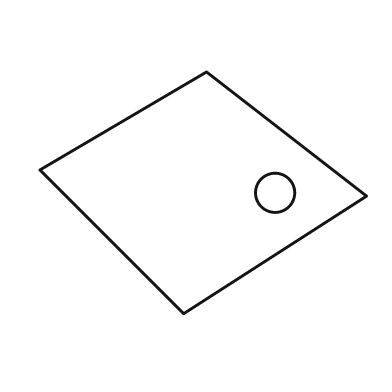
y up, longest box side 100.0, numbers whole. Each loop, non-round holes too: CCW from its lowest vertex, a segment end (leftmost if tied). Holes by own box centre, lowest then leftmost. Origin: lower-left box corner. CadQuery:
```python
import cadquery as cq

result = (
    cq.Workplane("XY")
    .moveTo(44.0, 0.0)
    .lineTo(100.0, 36.0)
    .lineTo(51.0, 74.0)
    .lineTo(0.0, 44.0)
    .close()
    .moveTo(72.0, 37.0)
    .circle(6.0)
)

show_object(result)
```